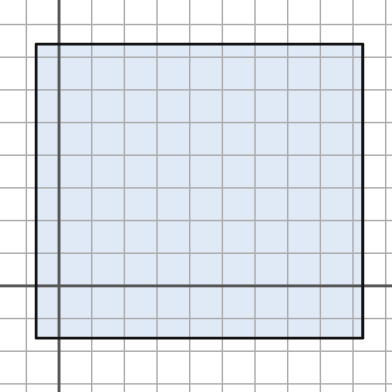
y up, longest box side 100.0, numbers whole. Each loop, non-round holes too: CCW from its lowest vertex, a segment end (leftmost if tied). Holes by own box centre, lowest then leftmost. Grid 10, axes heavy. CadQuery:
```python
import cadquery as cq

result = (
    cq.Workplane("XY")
    .moveTo(-7.0, -16.0)
    .lineTo(93.0, -16.0)
    .lineTo(93.0, 74.0)
    .lineTo(-7.0, 74.0)
    .close()
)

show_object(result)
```